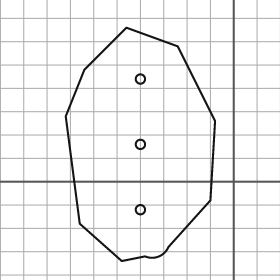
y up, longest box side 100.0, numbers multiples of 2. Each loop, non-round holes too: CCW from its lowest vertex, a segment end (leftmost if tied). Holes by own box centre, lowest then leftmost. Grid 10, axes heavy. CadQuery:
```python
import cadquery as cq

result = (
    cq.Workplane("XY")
    .moveTo(-48.0, -34.0)
    .lineTo(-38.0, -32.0)
    .threePointArc((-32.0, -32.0), (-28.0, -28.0))
    .lineTo(-10.0, -8.0)
    .lineTo(-8.0, 26.0)
    .lineTo(-24.0, 58.0)
    .lineTo(-46.0, 66.0)
    .lineTo(-64.0, 48.0)
    .lineTo(-72.0, 28.0)
    .lineTo(-66.0, -18.0)
    .close()
    .moveTo(-40.0, -12.0)
    .circle(2.0)
    .moveTo(-40.0, 16.0)
    .circle(2.0)
    .moveTo(-40.0, 44.0)
    .circle(2.0)
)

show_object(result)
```